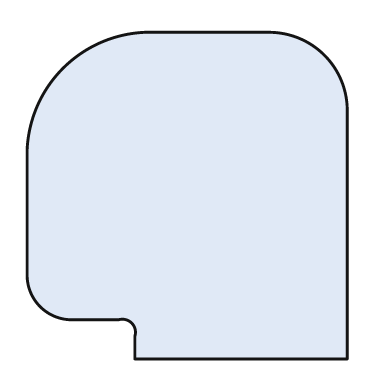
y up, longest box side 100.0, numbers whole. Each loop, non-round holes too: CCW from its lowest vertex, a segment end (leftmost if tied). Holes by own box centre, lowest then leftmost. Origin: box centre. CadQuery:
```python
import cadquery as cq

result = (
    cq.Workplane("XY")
    .moveTo(-16.0, -50.0)
    .lineTo(49.0, -50.0)
    .lineTo(49.0, 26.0)
    .threePointArc((42.0, 43.0), (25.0, 50.0))
    .lineTo(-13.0, 50.0)
    .threePointArc((-38.0, 39.0), (-49.0, 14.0))
    .lineTo(-49.0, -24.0)
    .threePointArc((-45.0, -34.0), (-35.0, -38.0))
    .lineTo(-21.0, -38.0)
    .threePointArc((-17.0, -39.0), (-16.0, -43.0))
    .close()
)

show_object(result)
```